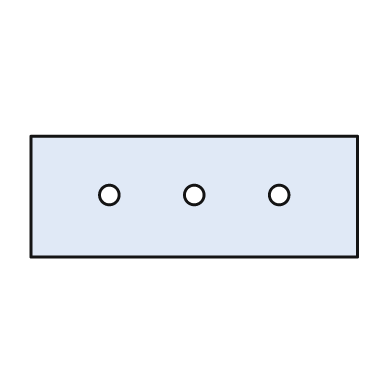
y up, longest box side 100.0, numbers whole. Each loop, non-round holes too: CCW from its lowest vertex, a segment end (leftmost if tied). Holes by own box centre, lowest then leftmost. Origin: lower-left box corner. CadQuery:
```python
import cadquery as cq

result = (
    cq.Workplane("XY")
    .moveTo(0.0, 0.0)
    .lineTo(100.0, 0.0)
    .lineTo(100.0, 37.0)
    .lineTo(0.0, 37.0)
    .close()
    .moveTo(24.0, 19.0)
    .circle(3.0)
    .moveTo(50.0, 19.0)
    .circle(3.0)
    .moveTo(76.0, 19.0)
    .circle(3.0)
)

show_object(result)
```